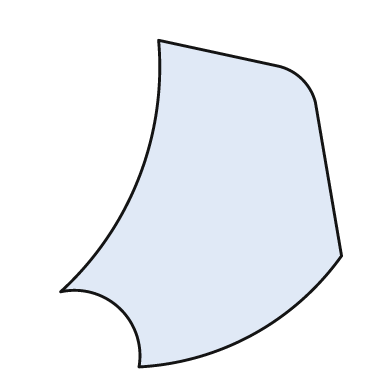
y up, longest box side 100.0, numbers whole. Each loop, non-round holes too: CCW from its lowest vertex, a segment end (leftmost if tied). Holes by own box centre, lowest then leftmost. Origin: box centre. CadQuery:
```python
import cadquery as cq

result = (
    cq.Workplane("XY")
    .moveTo(-19.0, -50.0)
    .threePointArc((16.0, -40.0), (43.0, -16.0))
    .lineTo(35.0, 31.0)
    .threePointArc((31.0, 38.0), (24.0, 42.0))
    .lineTo(-13.0, 50.0)
    .threePointArc((-19.0, 8.0), (-43.0, -27.0))
    .threePointArc((-25.0, -32.0), (-19.0, -50.0))
    .close()
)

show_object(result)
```